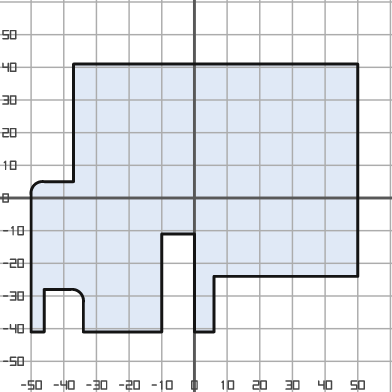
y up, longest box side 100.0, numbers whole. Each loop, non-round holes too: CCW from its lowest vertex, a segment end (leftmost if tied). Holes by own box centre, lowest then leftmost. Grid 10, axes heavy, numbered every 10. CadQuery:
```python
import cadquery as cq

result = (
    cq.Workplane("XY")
    .moveTo(-50.0, -41.0)
    .lineTo(-46.0, -41.0)
    .lineTo(-46.0, -28.0)
    .lineTo(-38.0, -28.0)
    .threePointArc((-35.0, -29.0), (-34.0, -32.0))
    .lineTo(-34.0, -41.0)
    .lineTo(-10.0, -41.0)
    .lineTo(-10.0, -11.0)
    .lineTo(0.0, -11.0)
    .lineTo(0.0, -41.0)
    .lineTo(6.0, -41.0)
    .lineTo(6.0, -24.0)
    .lineTo(50.0, -24.0)
    .lineTo(50.0, 41.0)
    .lineTo(-37.0, 41.0)
    .lineTo(-37.0, 5.0)
    .lineTo(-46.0, 5.0)
    .threePointArc((-49.0, 4.0), (-50.0, 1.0))
    .close()
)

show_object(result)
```